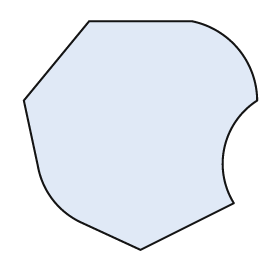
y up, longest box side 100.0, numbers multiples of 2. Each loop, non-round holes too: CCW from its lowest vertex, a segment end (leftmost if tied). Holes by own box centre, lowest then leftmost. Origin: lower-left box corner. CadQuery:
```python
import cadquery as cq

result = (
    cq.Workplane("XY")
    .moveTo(50.0, 0.0)
    .lineTo(90.0, 20.0)
    .threePointArc((86.0, 44.0), (100.0, 64.0))
    .threePointArc((92.0, 86.0), (72.0, 98.0))
    .lineTo(28.0, 98.0)
    .lineTo(0.0, 64.0)
    .lineTo(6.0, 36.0)
    .threePointArc((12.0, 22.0), (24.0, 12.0))
    .close()
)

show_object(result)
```